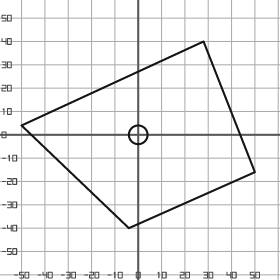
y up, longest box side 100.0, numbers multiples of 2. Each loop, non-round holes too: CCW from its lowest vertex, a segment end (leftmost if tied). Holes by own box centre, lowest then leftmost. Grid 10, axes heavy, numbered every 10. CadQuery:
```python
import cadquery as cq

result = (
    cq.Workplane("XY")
    .moveTo(-4.0, -40.0)
    .lineTo(50.0, -16.0)
    .lineTo(28.0, 40.0)
    .lineTo(-50.0, 4.0)
    .close()
    .moveTo(0.0, 0.0)
    .circle(4.0)
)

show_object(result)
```